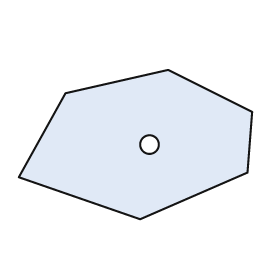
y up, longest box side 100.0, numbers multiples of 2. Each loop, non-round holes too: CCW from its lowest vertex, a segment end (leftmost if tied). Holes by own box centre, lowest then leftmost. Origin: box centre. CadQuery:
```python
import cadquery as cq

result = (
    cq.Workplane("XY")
    .moveTo(2.0, -32.0)
    .lineTo(48.0, -12.0)
    .lineTo(50.0, 14.0)
    .lineTo(14.0, 32.0)
    .lineTo(-30.0, 22.0)
    .lineTo(-50.0, -14.0)
    .close()
    .moveTo(6.0, 0.0)
    .circle(4.0)
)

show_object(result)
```